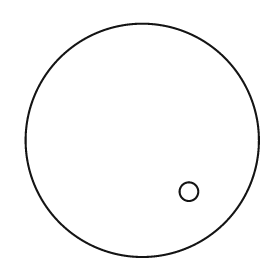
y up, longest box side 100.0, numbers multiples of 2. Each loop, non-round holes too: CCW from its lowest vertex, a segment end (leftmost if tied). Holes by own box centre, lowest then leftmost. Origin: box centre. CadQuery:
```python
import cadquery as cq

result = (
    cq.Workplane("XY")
    .moveTo(0.0, 0.0)
    .circle(50.0)
    .moveTo(20.0, -22.0)
    .circle(4.0)
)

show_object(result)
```